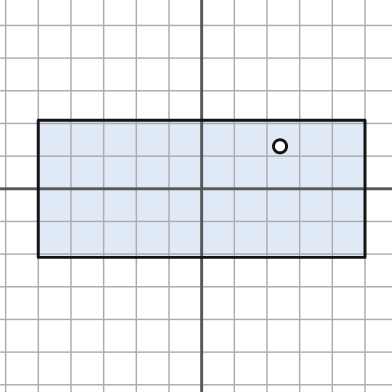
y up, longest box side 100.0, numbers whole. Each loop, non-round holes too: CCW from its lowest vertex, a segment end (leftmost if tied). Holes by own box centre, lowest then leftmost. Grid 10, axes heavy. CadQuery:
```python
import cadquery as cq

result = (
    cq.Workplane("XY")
    .moveTo(-50.0, -21.0)
    .lineTo(50.0, -21.0)
    .lineTo(50.0, 21.0)
    .lineTo(-50.0, 21.0)
    .close()
    .moveTo(24.0, 13.0)
    .circle(2.0)
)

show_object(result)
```